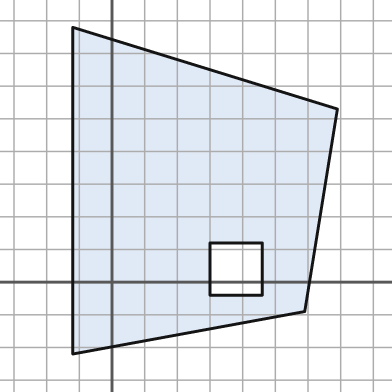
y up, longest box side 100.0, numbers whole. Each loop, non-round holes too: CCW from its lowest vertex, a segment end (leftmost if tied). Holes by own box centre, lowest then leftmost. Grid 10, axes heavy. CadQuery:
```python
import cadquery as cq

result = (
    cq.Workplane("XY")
    .moveTo(-12.0, -22.0)
    .lineTo(59.0, -9.0)
    .lineTo(69.0, 53.0)
    .lineTo(-12.0, 78.0)
    .close()
    .moveTo(30.0, -4.0)
    .lineTo(46.0, -4.0)
    .lineTo(46.0, 12.0)
    .lineTo(30.0, 12.0)
    .close()
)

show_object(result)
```